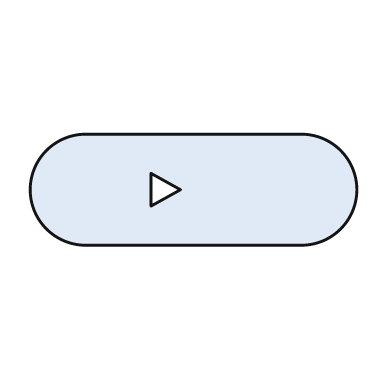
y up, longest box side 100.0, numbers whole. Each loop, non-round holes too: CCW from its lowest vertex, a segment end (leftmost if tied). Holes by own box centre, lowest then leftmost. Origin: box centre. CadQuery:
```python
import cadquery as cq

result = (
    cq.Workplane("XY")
    .moveTo(-33.0, -17.0)
    .lineTo(33.0, -17.0)
    .threePointArc((50.0, 0.0), (33.0, 17.0))
    .lineTo(-33.0, 17.0)
    .threePointArc((-50.0, 0.0), (-33.0, -17.0))
    .close()
    .moveTo(-13.0, -5.0)
    .lineTo(-4.0, 0.0)
    .lineTo(-13.0, 5.0)
    .close()
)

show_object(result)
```